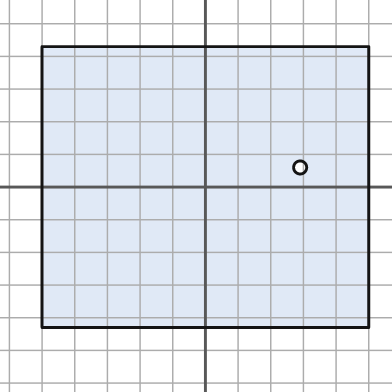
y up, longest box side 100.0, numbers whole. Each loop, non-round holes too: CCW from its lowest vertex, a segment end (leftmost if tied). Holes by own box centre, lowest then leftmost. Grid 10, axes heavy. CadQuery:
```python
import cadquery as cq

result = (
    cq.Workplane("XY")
    .moveTo(-50.0, -43.0)
    .lineTo(50.0, -43.0)
    .lineTo(50.0, 43.0)
    .lineTo(-50.0, 43.0)
    .close()
    .moveTo(29.0, 6.0)
    .circle(2.0)
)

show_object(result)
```